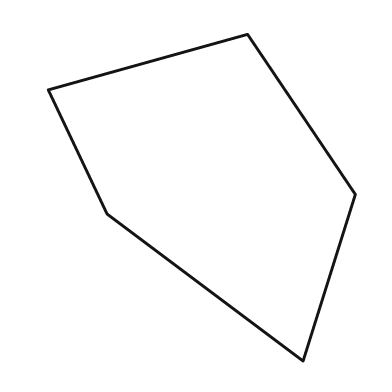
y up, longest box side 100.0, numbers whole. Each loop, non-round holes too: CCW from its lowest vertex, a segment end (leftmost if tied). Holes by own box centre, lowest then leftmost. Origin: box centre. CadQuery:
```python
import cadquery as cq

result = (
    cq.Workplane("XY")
    .moveTo(31.0, -50.0)
    .lineTo(47.0, 1.0)
    .lineTo(14.0, 50.0)
    .lineTo(-47.0, 33.0)
    .lineTo(-29.0, -5.0)
    .close()
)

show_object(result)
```